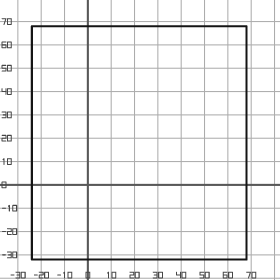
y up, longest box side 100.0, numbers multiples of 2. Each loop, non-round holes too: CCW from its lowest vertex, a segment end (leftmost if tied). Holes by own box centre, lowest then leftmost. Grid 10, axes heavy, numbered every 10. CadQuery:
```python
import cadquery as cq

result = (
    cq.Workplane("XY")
    .moveTo(-24.0, -32.0)
    .lineTo(68.0, -32.0)
    .lineTo(68.0, 68.0)
    .lineTo(-24.0, 68.0)
    .close()
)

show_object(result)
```